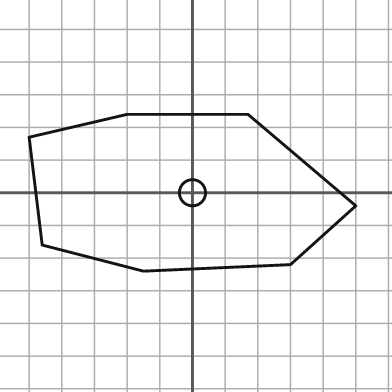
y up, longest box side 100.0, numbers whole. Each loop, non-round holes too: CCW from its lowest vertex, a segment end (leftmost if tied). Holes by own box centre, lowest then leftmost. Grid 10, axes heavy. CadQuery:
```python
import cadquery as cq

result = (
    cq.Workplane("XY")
    .moveTo(-15.0, -24.0)
    .lineTo(30.0, -22.0)
    .lineTo(50.0, -4.0)
    .lineTo(17.0, 24.0)
    .lineTo(-20.0, 24.0)
    .lineTo(-50.0, 17.0)
    .lineTo(-46.0, -16.0)
    .close()
    .moveTo(0.0, 0.0)
    .circle(4.0)
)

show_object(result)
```